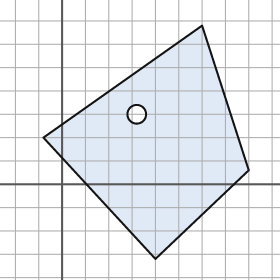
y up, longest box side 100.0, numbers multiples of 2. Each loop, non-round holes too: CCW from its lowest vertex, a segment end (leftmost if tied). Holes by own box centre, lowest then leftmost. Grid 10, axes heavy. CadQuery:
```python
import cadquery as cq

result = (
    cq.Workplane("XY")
    .moveTo(40.0, -32.0)
    .lineTo(80.0, 6.0)
    .lineTo(60.0, 68.0)
    .lineTo(-8.0, 20.0)
    .close()
    .moveTo(32.0, 30.0)
    .circle(4.0)
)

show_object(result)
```